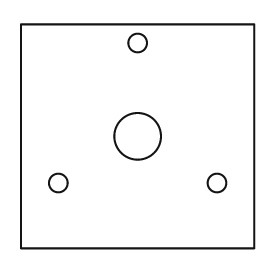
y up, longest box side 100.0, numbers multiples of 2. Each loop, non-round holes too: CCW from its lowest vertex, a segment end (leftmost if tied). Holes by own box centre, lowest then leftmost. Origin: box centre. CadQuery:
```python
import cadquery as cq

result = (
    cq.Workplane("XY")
    .moveTo(-50.0, -48.0)
    .lineTo(50.0, -48.0)
    .lineTo(50.0, 48.0)
    .lineTo(-50.0, 48.0)
    .close()
    .moveTo(-34.0, -20.0)
    .circle(4.0)
    .moveTo(34.0, -20.0)
    .circle(4.0)
    .moveTo(0.0, 0.0)
    .circle(10.0)
    .moveTo(0.0, 40.0)
    .circle(4.0)
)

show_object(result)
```